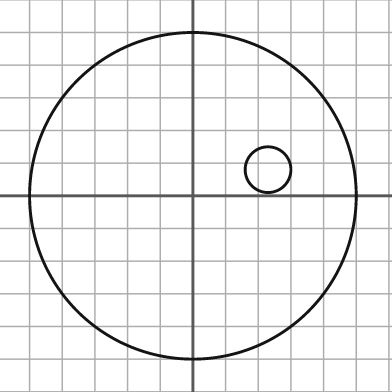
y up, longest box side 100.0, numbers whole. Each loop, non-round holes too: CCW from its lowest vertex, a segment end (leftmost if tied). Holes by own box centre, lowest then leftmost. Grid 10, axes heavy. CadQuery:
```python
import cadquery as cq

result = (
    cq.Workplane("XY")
    .moveTo(0.0, 0.0)
    .circle(50.0)
    .moveTo(23.0, 8.0)
    .circle(7.0)
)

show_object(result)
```